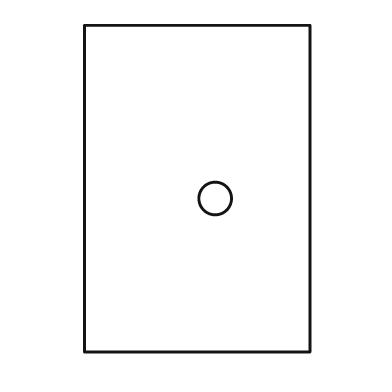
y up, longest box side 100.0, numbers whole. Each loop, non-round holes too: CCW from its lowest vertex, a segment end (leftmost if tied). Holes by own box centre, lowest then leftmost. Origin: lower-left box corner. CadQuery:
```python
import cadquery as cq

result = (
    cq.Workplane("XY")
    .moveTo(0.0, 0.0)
    .lineTo(69.0, 0.0)
    .lineTo(69.0, 100.0)
    .lineTo(0.0, 100.0)
    .close()
    .moveTo(40.0, 47.0)
    .circle(5.0)
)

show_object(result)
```